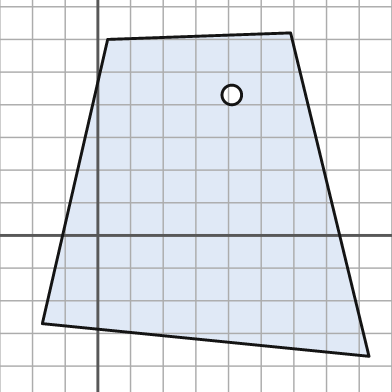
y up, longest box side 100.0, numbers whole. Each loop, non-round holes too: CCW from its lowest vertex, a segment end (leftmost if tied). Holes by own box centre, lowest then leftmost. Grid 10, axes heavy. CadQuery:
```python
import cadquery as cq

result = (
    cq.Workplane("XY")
    .moveTo(83.0, -37.0)
    .lineTo(59.0, 62.0)
    .lineTo(3.0, 60.0)
    .lineTo(-17.0, -27.0)
    .close()
    .moveTo(41.0, 43.0)
    .circle(3.0)
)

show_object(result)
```